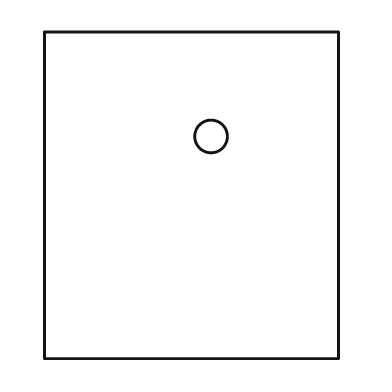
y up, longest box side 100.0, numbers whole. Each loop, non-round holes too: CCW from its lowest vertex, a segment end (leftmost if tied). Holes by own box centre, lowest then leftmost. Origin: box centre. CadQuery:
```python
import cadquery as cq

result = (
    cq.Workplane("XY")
    .moveTo(-45.0, -50.0)
    .lineTo(45.0, -50.0)
    .lineTo(45.0, 50.0)
    .lineTo(-45.0, 50.0)
    .close()
    .moveTo(6.0, 18.0)
    .circle(5.0)
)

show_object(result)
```